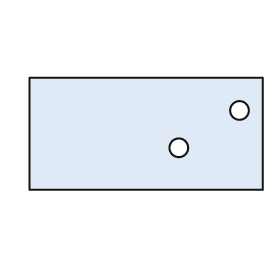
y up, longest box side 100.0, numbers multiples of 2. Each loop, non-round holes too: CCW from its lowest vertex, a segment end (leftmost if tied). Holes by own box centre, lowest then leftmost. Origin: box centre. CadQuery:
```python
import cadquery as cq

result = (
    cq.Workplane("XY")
    .moveTo(-50.0, -24.0)
    .lineTo(50.0, -24.0)
    .lineTo(50.0, 24.0)
    .lineTo(-50.0, 24.0)
    .close()
    .moveTo(14.0, -6.0)
    .circle(4.0)
    .moveTo(40.0, 10.0)
    .circle(4.0)
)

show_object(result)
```